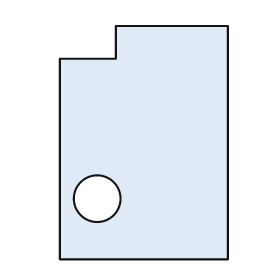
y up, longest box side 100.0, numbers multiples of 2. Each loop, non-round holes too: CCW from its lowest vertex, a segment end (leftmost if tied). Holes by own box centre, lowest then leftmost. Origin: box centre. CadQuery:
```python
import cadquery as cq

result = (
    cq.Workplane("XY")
    .moveTo(-36.0, -50.0)
    .lineTo(36.0, -50.0)
    .lineTo(36.0, 50.0)
    .lineTo(-12.0, 50.0)
    .lineTo(-12.0, 36.0)
    .lineTo(-36.0, 36.0)
    .close()
    .moveTo(-20.0, -24.0)
    .circle(10.0)
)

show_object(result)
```